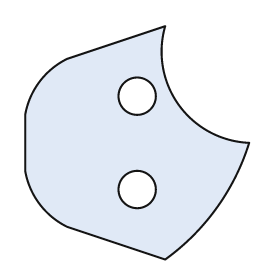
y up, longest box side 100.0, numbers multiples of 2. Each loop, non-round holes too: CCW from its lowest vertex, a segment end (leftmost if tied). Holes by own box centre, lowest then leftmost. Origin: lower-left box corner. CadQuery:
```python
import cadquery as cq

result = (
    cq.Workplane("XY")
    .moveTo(60.0, 0.0)
    .threePointArc((82.0, 22.0), (96.0, 50.0))
    .threePointArc((66.0, 66.0), (60.0, 100.0))
    .lineTo(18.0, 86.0)
    .threePointArc((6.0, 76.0), (0.0, 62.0))
    .lineTo(0.0, 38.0)
    .threePointArc((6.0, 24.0), (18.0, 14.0))
    .close()
    .moveTo(48.0, 30.0)
    .circle(8.0)
    .moveTo(48.0, 70.0)
    .circle(8.0)
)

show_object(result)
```